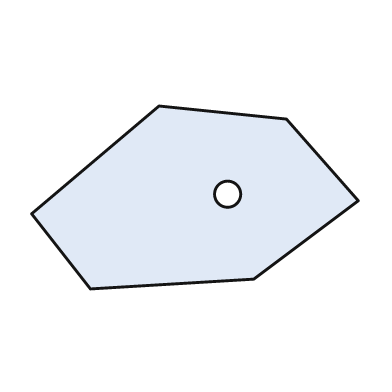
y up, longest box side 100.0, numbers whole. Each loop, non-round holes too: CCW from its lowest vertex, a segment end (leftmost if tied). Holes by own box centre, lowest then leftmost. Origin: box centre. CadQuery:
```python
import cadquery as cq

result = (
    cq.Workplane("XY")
    .moveTo(-32.0, -28.0)
    .lineTo(18.0, -25.0)
    .lineTo(50.0, -1.0)
    .lineTo(28.0, 24.0)
    .lineTo(-11.0, 28.0)
    .lineTo(-50.0, -5.0)
    .close()
    .moveTo(10.0, 1.0)
    .circle(4.0)
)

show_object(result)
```